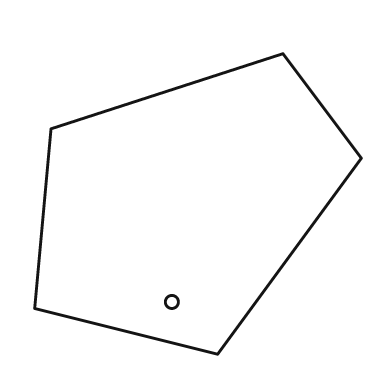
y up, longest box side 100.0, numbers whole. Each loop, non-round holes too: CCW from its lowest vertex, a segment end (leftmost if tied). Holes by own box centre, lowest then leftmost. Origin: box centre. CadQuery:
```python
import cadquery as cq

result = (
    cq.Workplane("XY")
    .moveTo(6.0, -46.0)
    .lineTo(50.0, 14.0)
    .lineTo(26.0, 46.0)
    .lineTo(-45.0, 23.0)
    .lineTo(-50.0, -32.0)
    .close()
    .moveTo(-8.0, -30.0)
    .circle(2.0)
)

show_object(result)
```